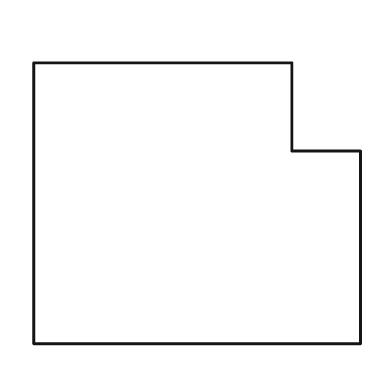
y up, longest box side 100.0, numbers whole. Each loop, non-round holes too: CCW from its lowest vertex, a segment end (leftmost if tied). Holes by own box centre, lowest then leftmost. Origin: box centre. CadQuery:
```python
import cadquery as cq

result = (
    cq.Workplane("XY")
    .moveTo(-50.0, -43.0)
    .lineTo(50.0, -43.0)
    .lineTo(50.0, 16.0)
    .lineTo(29.0, 16.0)
    .lineTo(29.0, 43.0)
    .lineTo(-50.0, 43.0)
    .close()
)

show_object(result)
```